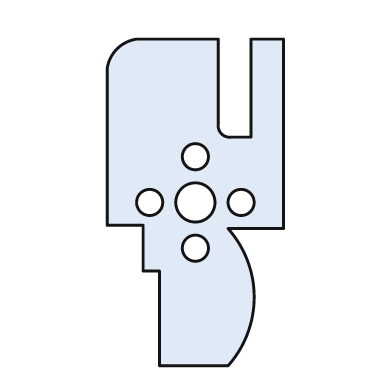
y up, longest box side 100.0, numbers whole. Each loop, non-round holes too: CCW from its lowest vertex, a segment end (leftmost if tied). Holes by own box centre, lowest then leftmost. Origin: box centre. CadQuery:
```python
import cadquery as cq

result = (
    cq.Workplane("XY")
    .moveTo(-11.0, -50.0)
    .lineTo(10.0, -50.0)
    .threePointArc((18.0, -29.0), (10.0, -8.0))
    .lineTo(27.0, -8.0)
    .lineTo(27.0, 50.0)
    .lineTo(17.0, 50.0)
    .lineTo(17.0, 20.0)
    .lineTo(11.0, 20.0)
    .threePointArc((8.0, 21.0), (7.0, 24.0))
    .lineTo(7.0, 50.0)
    .lineTo(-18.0, 50.0)
    .threePointArc((-24.0, 47.0), (-27.0, 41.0))
    .lineTo(-27.0, -7.0)
    .lineTo(-16.0, -7.0)
    .lineTo(-16.0, -21.0)
    .lineTo(-11.0, -21.0)
    .close()
    .moveTo(0.0, -14.0)
    .circle(4.0)
    .moveTo(-14.0, 0.0)
    .circle(4.0)
    .moveTo(0.0, 0.0)
    .circle(6.0)
    .moveTo(14.0, 0.0)
    .circle(4.0)
    .moveTo(0.0, 14.0)
    .circle(4.0)
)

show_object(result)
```